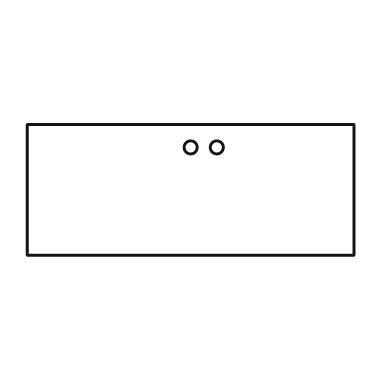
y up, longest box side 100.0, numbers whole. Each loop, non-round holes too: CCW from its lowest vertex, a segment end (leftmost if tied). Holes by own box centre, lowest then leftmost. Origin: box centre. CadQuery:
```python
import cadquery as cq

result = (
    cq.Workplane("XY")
    .moveTo(-50.0, -20.0)
    .lineTo(50.0, -20.0)
    .lineTo(50.0, 20.0)
    .lineTo(-50.0, 20.0)
    .close()
    .moveTo(0.0, 13.0)
    .circle(2.0)
    .moveTo(8.0, 13.0)
    .circle(2.0)
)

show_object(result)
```